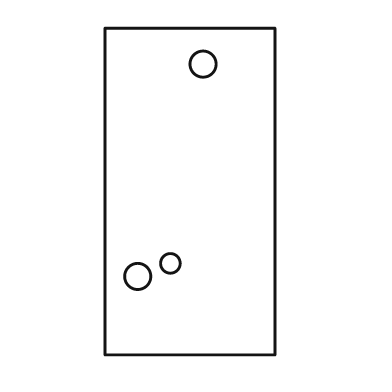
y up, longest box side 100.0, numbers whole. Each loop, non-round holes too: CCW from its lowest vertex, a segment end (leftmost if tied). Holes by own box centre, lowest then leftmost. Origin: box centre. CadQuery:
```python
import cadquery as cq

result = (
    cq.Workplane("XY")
    .moveTo(-26.0, -50.0)
    .lineTo(26.0, -50.0)
    .lineTo(26.0, 50.0)
    .lineTo(-26.0, 50.0)
    .close()
    .moveTo(-16.0, -26.0)
    .circle(4.0)
    .moveTo(-6.0, -22.0)
    .circle(3.0)
    .moveTo(4.0, 39.0)
    .circle(4.0)
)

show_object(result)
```